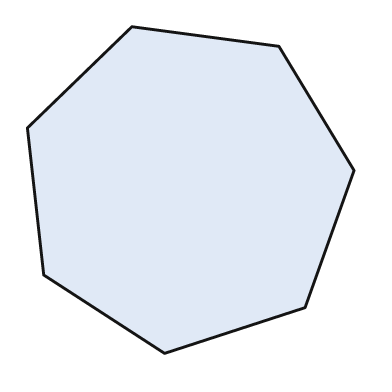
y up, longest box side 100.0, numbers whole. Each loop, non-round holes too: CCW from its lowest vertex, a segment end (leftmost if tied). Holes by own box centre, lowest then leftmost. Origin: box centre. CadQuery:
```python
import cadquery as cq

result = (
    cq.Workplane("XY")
    .moveTo(-8.0, -50.0)
    .lineTo(35.0, -36.0)
    .lineTo(50.0, 6.0)
    .lineTo(27.0, 44.0)
    .lineTo(-18.0, 50.0)
    .lineTo(-50.0, 19.0)
    .lineTo(-45.0, -26.0)
    .close()
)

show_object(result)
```